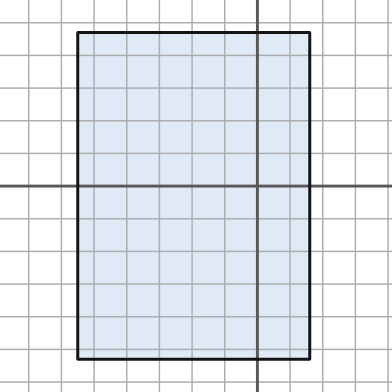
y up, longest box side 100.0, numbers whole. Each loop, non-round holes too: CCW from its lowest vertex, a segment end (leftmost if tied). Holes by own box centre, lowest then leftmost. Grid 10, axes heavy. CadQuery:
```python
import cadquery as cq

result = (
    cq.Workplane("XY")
    .moveTo(-55.0, -53.0)
    .lineTo(16.0, -53.0)
    .lineTo(16.0, 47.0)
    .lineTo(-55.0, 47.0)
    .close()
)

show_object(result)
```